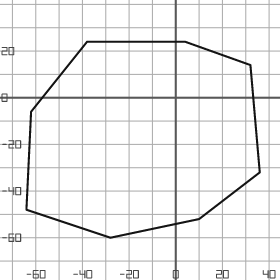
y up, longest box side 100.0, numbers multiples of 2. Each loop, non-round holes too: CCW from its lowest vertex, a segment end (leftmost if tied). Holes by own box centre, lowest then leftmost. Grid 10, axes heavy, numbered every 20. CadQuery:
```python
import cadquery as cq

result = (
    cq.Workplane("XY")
    .moveTo(-28.0, -60.0)
    .lineTo(10.0, -52.0)
    .lineTo(36.0, -32.0)
    .lineTo(32.0, 14.0)
    .lineTo(4.0, 24.0)
    .lineTo(-38.0, 24.0)
    .lineTo(-62.0, -6.0)
    .lineTo(-64.0, -48.0)
    .close()
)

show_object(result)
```